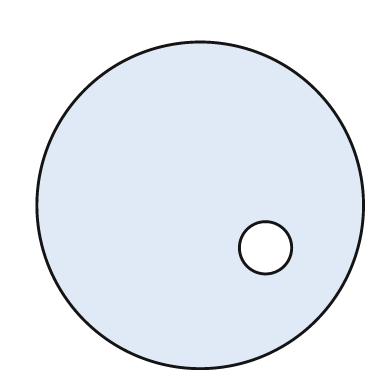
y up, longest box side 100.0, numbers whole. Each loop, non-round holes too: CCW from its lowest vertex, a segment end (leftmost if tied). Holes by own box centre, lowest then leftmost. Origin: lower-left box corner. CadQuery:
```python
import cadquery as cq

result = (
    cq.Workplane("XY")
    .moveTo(50.0, 50.0)
    .circle(50.0)
    .moveTo(70.0, 37.0)
    .circle(8.0)
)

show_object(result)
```